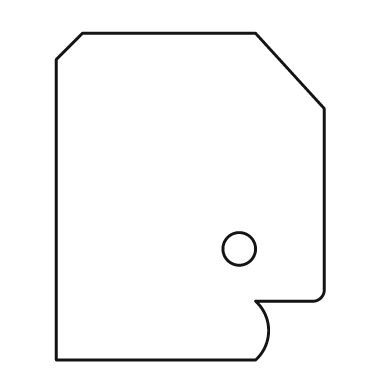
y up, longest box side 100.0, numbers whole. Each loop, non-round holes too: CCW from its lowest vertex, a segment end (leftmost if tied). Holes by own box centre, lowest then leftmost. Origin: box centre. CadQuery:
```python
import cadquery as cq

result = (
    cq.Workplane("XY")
    .moveTo(-41.0, -50.0)
    .lineTo(20.0, -50.0)
    .threePointArc((24.0, -41.0), (20.0, -32.0))
    .lineTo(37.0, -32.0)
    .threePointArc((40.0, -31.0), (41.0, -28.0))
    .lineTo(41.0, 27.0)
    .lineTo(20.0, 50.0)
    .lineTo(-33.0, 50.0)
    .lineTo(-41.0, 42.0)
    .close()
    .moveTo(15.0, -16.0)
    .circle(5.0)
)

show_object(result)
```